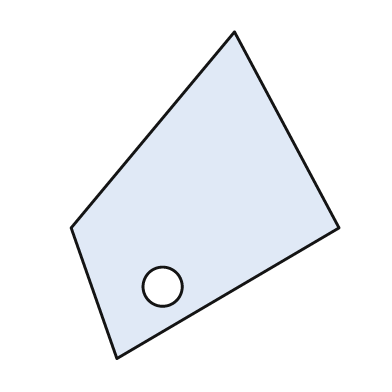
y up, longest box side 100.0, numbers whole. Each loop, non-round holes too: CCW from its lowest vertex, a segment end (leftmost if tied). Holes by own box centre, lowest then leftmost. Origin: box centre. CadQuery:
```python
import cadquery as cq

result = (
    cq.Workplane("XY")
    .moveTo(-27.0, -50.0)
    .lineTo(41.0, -10.0)
    .lineTo(9.0, 50.0)
    .lineTo(-41.0, -10.0)
    .close()
    .moveTo(-13.0, -28.0)
    .circle(6.0)
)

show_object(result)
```